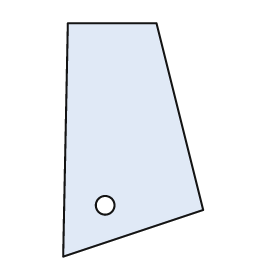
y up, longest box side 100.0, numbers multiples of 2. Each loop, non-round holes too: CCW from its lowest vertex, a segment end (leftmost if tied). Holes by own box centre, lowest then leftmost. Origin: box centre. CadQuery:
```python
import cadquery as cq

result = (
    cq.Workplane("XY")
    .moveTo(-30.0, -50.0)
    .lineTo(30.0, -30.0)
    .lineTo(10.0, 50.0)
    .lineTo(-28.0, 50.0)
    .close()
    .moveTo(-12.0, -28.0)
    .circle(4.0)
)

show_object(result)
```